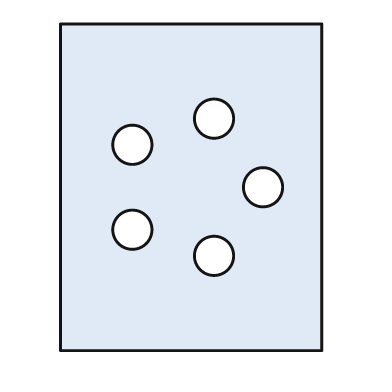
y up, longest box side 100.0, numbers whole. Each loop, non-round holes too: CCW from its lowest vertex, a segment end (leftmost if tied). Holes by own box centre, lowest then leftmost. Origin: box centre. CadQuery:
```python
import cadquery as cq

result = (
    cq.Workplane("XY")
    .moveTo(-40.0, -50.0)
    .lineTo(40.0, -50.0)
    .lineTo(40.0, 50.0)
    .lineTo(-40.0, 50.0)
    .close()
    .moveTo(7.0, -21.0)
    .circle(6.0)
    .moveTo(-18.0, -13.0)
    .circle(6.0)
    .moveTo(22.0, 0.0)
    .circle(6.0)
    .moveTo(-18.0, 13.0)
    .circle(6.0)
    .moveTo(7.0, 21.0)
    .circle(6.0)
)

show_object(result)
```